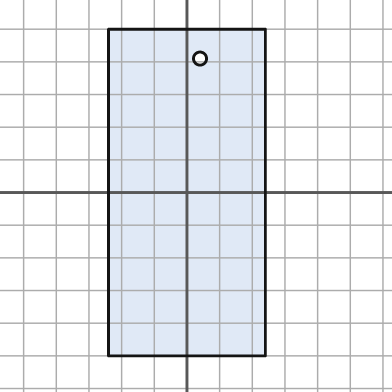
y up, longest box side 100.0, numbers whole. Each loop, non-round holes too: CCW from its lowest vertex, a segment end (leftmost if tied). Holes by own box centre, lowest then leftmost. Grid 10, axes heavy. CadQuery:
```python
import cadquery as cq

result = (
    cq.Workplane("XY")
    .moveTo(-24.0, -50.0)
    .lineTo(24.0, -50.0)
    .lineTo(24.0, 50.0)
    .lineTo(-24.0, 50.0)
    .close()
    .moveTo(4.0, 41.0)
    .circle(2.0)
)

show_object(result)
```